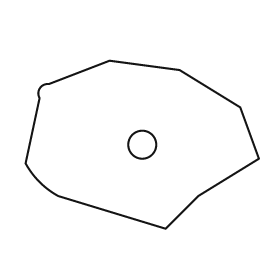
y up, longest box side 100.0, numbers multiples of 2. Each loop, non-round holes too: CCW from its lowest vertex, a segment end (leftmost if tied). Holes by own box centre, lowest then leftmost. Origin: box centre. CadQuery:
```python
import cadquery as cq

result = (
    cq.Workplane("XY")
    .moveTo(10.0, -36.0)
    .lineTo(24.0, -22.0)
    .lineTo(50.0, -6.0)
    .lineTo(42.0, 16.0)
    .lineTo(16.0, 32.0)
    .lineTo(-14.0, 36.0)
    .lineTo(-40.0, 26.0)
    .threePointArc((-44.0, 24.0), (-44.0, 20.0))
    .lineTo(-50.0, -8.0)
    .threePointArc((-44.0, -16.0), (-36.0, -22.0))
    .close()
    .moveTo(0.0, 0.0)
    .circle(6.0)
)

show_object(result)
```